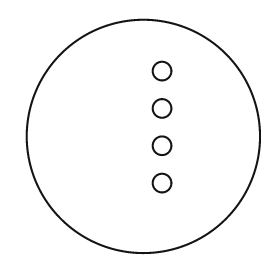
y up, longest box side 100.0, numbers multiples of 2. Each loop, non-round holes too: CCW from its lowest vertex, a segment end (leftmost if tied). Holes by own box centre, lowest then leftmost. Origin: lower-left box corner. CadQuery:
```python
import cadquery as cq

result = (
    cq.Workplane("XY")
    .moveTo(50.0, 50.0)
    .circle(50.0)
    .moveTo(58.0, 30.0)
    .circle(4.0)
    .moveTo(58.0, 46.0)
    .circle(4.0)
    .moveTo(58.0, 62.0)
    .circle(4.0)
    .moveTo(58.0, 78.0)
    .circle(4.0)
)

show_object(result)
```